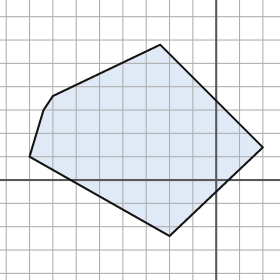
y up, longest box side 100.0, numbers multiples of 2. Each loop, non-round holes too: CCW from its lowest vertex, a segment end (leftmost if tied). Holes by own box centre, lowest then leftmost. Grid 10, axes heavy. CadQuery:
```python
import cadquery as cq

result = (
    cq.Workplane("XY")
    .moveTo(-20.0, -24.0)
    .lineTo(20.0, 14.0)
    .lineTo(-24.0, 58.0)
    .lineTo(-70.0, 36.0)
    .lineTo(-74.0, 30.0)
    .lineTo(-80.0, 10.0)
    .close()
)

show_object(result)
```